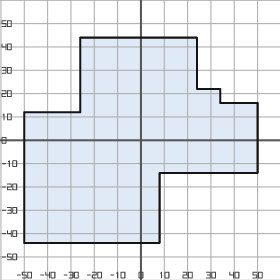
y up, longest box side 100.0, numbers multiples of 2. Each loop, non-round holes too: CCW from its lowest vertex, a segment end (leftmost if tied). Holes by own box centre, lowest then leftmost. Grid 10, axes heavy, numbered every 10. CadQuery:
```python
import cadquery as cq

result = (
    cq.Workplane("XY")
    .moveTo(-50.0, -44.0)
    .lineTo(8.0, -44.0)
    .lineTo(8.0, -14.0)
    .lineTo(50.0, -14.0)
    .lineTo(50.0, 16.0)
    .lineTo(34.0, 16.0)
    .lineTo(34.0, 22.0)
    .lineTo(24.0, 22.0)
    .lineTo(24.0, 44.0)
    .lineTo(-26.0, 44.0)
    .lineTo(-26.0, 12.0)
    .lineTo(-50.0, 12.0)
    .close()
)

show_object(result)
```